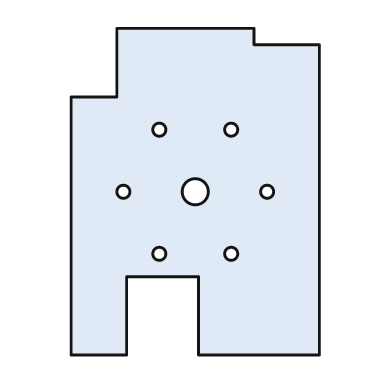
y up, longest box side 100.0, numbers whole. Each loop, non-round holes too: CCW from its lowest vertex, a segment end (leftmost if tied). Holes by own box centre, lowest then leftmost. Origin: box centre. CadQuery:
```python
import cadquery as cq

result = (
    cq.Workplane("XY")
    .moveTo(-38.0, -50.0)
    .lineTo(-21.0, -50.0)
    .lineTo(-21.0, -26.0)
    .lineTo(1.0, -26.0)
    .lineTo(1.0, -50.0)
    .lineTo(38.0, -50.0)
    .lineTo(38.0, 45.0)
    .lineTo(18.0, 45.0)
    .lineTo(18.0, 50.0)
    .lineTo(-24.0, 50.0)
    .lineTo(-24.0, 29.0)
    .lineTo(-38.0, 29.0)
    .close()
    .moveTo(-11.0, -19.0)
    .circle(2.0)
    .moveTo(11.0, -19.0)
    .circle(2.0)
    .moveTo(-22.0, 0.0)
    .circle(2.0)
    .moveTo(0.0, 0.0)
    .circle(4.0)
    .moveTo(22.0, 0.0)
    .circle(2.0)
    .moveTo(-11.0, 19.0)
    .circle(2.0)
    .moveTo(11.0, 19.0)
    .circle(2.0)
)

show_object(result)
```